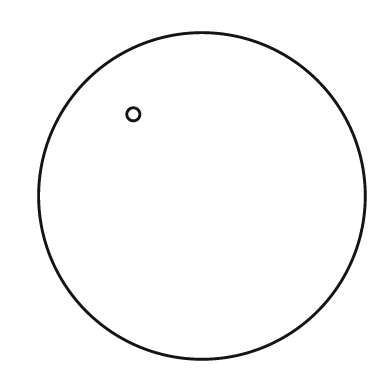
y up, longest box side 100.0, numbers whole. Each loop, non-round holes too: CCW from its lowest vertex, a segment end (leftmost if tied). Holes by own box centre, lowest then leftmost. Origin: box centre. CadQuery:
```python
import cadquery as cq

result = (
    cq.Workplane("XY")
    .moveTo(0.0, 0.0)
    .circle(50.0)
    .moveTo(-21.0, 25.0)
    .circle(2.0)
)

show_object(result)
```